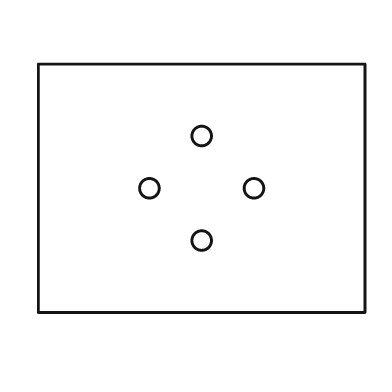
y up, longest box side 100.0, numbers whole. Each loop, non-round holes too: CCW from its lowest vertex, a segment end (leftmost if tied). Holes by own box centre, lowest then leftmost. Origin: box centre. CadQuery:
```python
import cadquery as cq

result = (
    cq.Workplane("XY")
    .moveTo(-50.0, -38.0)
    .lineTo(50.0, -38.0)
    .lineTo(50.0, 38.0)
    .lineTo(-50.0, 38.0)
    .close()
    .moveTo(0.0, -16.0)
    .circle(3.0)
    .moveTo(-16.0, 0.0)
    .circle(3.0)
    .moveTo(16.0, 0.0)
    .circle(3.0)
    .moveTo(0.0, 16.0)
    .circle(3.0)
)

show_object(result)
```